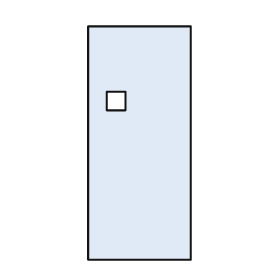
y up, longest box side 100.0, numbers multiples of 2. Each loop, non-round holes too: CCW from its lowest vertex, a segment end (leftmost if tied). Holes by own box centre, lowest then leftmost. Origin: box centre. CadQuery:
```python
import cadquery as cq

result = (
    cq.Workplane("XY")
    .moveTo(-22.0, -50.0)
    .lineTo(22.0, -50.0)
    .lineTo(22.0, 50.0)
    .lineTo(-22.0, 50.0)
    .close()
    .moveTo(-14.0, 14.0)
    .lineTo(-6.0, 14.0)
    .lineTo(-6.0, 22.0)
    .lineTo(-14.0, 22.0)
    .close()
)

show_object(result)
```